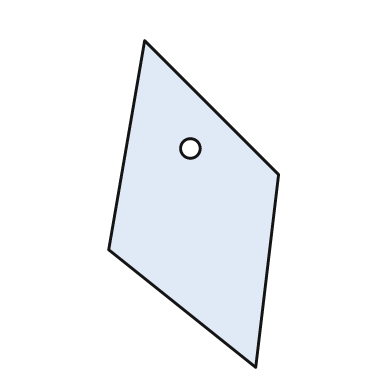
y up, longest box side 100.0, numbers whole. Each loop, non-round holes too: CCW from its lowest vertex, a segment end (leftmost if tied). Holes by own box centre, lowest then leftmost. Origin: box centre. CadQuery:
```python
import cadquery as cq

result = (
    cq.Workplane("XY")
    .moveTo(19.0, -50.0)
    .lineTo(26.0, 9.0)
    .lineTo(-15.0, 50.0)
    .lineTo(-26.0, -14.0)
    .close()
    .moveTo(-1.0, 17.0)
    .circle(3.0)
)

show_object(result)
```